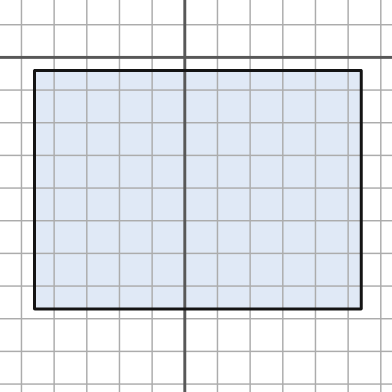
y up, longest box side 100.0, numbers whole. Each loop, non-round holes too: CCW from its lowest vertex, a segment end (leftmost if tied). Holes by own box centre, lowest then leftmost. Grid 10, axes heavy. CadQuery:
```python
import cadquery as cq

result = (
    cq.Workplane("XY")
    .moveTo(-46.0, -77.0)
    .lineTo(54.0, -77.0)
    .lineTo(54.0, -4.0)
    .lineTo(-46.0, -4.0)
    .close()
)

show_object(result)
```